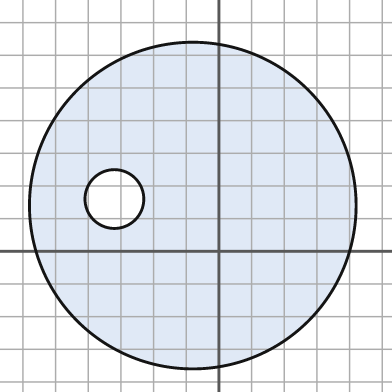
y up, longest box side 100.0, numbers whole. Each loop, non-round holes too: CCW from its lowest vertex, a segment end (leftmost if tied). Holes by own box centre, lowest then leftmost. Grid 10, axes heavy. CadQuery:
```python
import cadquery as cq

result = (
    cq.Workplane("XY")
    .moveTo(-8.0, 14.0)
    .circle(50.0)
    .moveTo(-32.0, 16.0)
    .circle(9.0)
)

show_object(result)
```